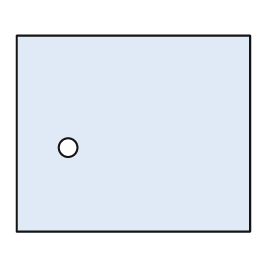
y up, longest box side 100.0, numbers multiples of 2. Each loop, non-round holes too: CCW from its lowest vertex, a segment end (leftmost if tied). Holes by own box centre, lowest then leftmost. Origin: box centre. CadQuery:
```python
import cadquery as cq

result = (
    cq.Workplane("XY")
    .moveTo(-50.0, -42.0)
    .lineTo(50.0, -42.0)
    .lineTo(50.0, 42.0)
    .lineTo(-50.0, 42.0)
    .close()
    .moveTo(-28.0, -6.0)
    .circle(4.0)
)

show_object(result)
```